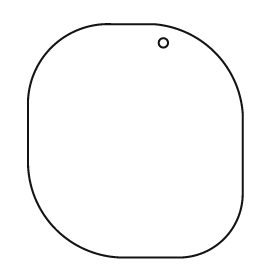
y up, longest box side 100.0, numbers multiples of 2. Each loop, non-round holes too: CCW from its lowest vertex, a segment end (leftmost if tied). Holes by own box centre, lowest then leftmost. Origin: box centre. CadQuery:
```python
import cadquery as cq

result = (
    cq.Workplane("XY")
    .moveTo(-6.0, -50.0)
    .lineTo(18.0, -50.0)
    .threePointArc((38.0, -42.0), (46.0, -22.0))
    .lineTo(46.0, 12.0)
    .threePointArc((34.0, 38.0), (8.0, 50.0))
    .lineTo(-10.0, 50.0)
    .threePointArc((-36.0, 40.0), (-46.0, 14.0))
    .lineTo(-46.0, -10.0)
    .threePointArc((-34.0, -38.0), (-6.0, -50.0))
    .close()
    .moveTo(12.0, 42.0)
    .circle(2.0)
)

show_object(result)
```